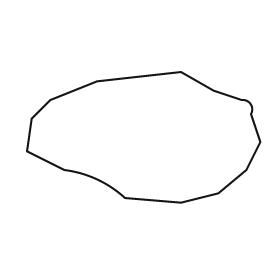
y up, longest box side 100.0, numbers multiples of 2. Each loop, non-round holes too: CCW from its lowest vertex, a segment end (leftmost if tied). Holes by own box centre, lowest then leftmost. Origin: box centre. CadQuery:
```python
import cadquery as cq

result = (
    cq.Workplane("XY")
    .moveTo(16.0, -28.0)
    .lineTo(32.0, -24.0)
    .lineTo(44.0, -14.0)
    .lineTo(50.0, -2.0)
    .lineTo(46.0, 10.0)
    .threePointArc((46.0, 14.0), (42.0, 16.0))
    .lineTo(30.0, 20.0)
    .lineTo(16.0, 28.0)
    .lineTo(-20.0, 24.0)
    .lineTo(-40.0, 16.0)
    .lineTo(-48.0, 8.0)
    .lineTo(-50.0, -6.0)
    .lineTo(-34.0, -14.0)
    .threePointArc((-20.0, -18.0), (-8.0, -26.0))
    .close()
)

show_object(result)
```